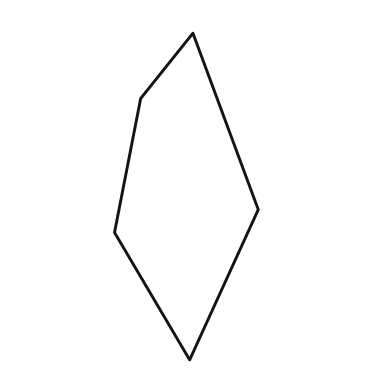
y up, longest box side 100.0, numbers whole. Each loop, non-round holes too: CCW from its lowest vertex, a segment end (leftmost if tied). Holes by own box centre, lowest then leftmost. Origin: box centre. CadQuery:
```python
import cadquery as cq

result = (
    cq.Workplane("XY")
    .moveTo(1.0, -50.0)
    .lineTo(22.0, -4.0)
    .lineTo(2.0, 50.0)
    .lineTo(-14.0, 30.0)
    .lineTo(-22.0, -11.0)
    .close()
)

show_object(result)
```